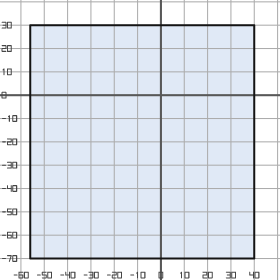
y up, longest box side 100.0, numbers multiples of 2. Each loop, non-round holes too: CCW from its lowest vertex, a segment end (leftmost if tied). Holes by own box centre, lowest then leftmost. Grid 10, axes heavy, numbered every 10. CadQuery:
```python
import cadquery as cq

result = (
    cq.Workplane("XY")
    .moveTo(-56.0, -70.0)
    .lineTo(40.0, -70.0)
    .lineTo(40.0, 30.0)
    .lineTo(-56.0, 30.0)
    .close()
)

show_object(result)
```